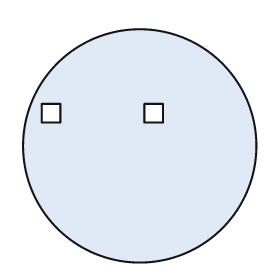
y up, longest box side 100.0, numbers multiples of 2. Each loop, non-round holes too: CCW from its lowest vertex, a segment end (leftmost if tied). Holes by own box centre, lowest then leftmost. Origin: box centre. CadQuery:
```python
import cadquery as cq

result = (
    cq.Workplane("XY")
    .moveTo(0.0, 0.0)
    .circle(50.0)
    .moveTo(-42.0, 10.0)
    .lineTo(-34.0, 10.0)
    .lineTo(-34.0, 18.0)
    .lineTo(-42.0, 18.0)
    .close()
    .moveTo(2.0, 10.0)
    .lineTo(10.0, 10.0)
    .lineTo(10.0, 18.0)
    .lineTo(2.0, 18.0)
    .close()
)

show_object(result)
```